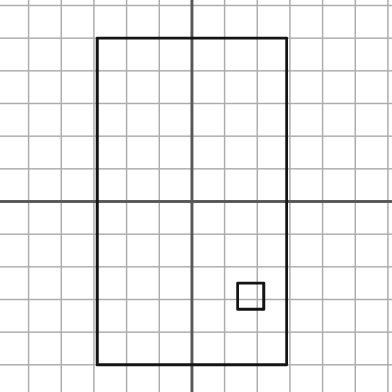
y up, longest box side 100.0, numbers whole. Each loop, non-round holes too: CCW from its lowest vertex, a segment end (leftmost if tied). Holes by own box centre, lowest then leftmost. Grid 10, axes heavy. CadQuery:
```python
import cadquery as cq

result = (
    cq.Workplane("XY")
    .moveTo(-29.0, -50.0)
    .lineTo(29.0, -50.0)
    .lineTo(29.0, 50.0)
    .lineTo(-29.0, 50.0)
    .close()
    .moveTo(14.0, -33.0)
    .lineTo(22.0, -33.0)
    .lineTo(22.0, -25.0)
    .lineTo(14.0, -25.0)
    .close()
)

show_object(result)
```